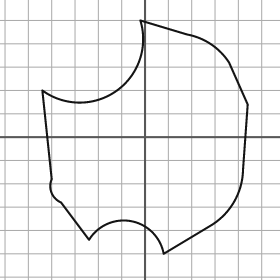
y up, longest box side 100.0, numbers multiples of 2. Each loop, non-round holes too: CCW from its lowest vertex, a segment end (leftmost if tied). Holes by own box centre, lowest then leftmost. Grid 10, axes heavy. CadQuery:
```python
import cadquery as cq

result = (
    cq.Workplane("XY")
    .moveTo(8.0, -50.0)
    .lineTo(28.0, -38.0)
    .threePointArc((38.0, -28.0), (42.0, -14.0))
    .lineTo(44.0, 14.0)
    .lineTo(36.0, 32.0)
    .threePointArc((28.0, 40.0), (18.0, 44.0))
    .lineTo(-2.0, 50.0)
    .threePointArc((-12.0, 20.0), (-44.0, 20.0))
    .lineTo(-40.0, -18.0)
    .threePointArc((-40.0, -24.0), (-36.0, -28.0))
    .lineTo(-24.0, -44.0)
    .threePointArc((-6.0, -36.0), (8.0, -50.0))
    .close()
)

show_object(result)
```